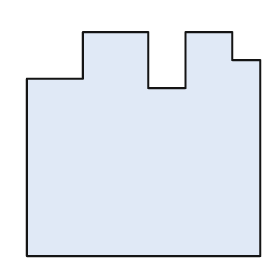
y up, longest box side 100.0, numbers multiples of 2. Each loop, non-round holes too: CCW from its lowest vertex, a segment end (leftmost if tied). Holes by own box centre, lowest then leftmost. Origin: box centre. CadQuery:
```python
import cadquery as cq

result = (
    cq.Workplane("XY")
    .moveTo(-50.0, -48.0)
    .lineTo(50.0, -48.0)
    .lineTo(50.0, 36.0)
    .lineTo(38.0, 36.0)
    .lineTo(38.0, 48.0)
    .lineTo(18.0, 48.0)
    .lineTo(18.0, 24.0)
    .lineTo(2.0, 24.0)
    .lineTo(2.0, 48.0)
    .lineTo(-26.0, 48.0)
    .lineTo(-26.0, 28.0)
    .lineTo(-50.0, 28.0)
    .close()
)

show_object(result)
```